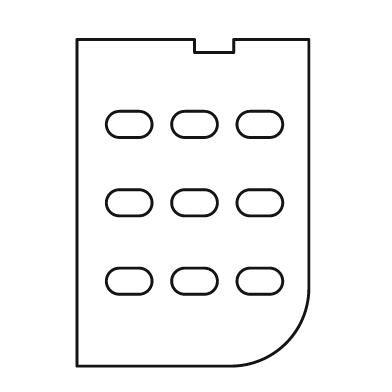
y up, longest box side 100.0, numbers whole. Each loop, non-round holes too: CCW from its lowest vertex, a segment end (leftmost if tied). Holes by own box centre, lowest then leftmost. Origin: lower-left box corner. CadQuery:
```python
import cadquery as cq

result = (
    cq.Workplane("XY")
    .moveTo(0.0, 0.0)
    .lineTo(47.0, 0.0)
    .threePointArc((64.0, 7.0), (71.0, 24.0))
    .lineTo(71.0, 100.0)
    .lineTo(48.0, 100.0)
    .lineTo(48.0, 96.0)
    .lineTo(36.0, 96.0)
    .lineTo(36.0, 100.0)
    .lineTo(0.0, 100.0)
    .close()
    .moveTo(13.0, 22.0)
    .lineTo(19.0, 22.0)
    .threePointArc((23.0, 26.0), (19.0, 30.0))
    .lineTo(13.0, 30.0)
    .threePointArc((9.0, 26.0), (13.0, 22.0))
    .close()
    .moveTo(33.0, 22.0)
    .lineTo(39.0, 22.0)
    .threePointArc((43.0, 26.0), (39.0, 30.0))
    .lineTo(33.0, 30.0)
    .threePointArc((29.0, 26.0), (33.0, 22.0))
    .close()
    .moveTo(53.0, 22.0)
    .lineTo(59.0, 22.0)
    .threePointArc((63.0, 26.0), (59.0, 30.0))
    .lineTo(53.0, 30.0)
    .threePointArc((49.0, 26.0), (53.0, 22.0))
    .close()
    .moveTo(13.0, 46.0)
    .lineTo(19.0, 46.0)
    .threePointArc((23.0, 50.0), (19.0, 54.0))
    .lineTo(13.0, 54.0)
    .threePointArc((9.0, 50.0), (13.0, 46.0))
    .close()
    .moveTo(33.0, 46.0)
    .lineTo(39.0, 46.0)
    .threePointArc((43.0, 50.0), (39.0, 54.0))
    .lineTo(33.0, 54.0)
    .threePointArc((29.0, 50.0), (33.0, 46.0))
    .close()
    .moveTo(53.0, 46.0)
    .lineTo(59.0, 46.0)
    .threePointArc((63.0, 50.0), (59.0, 54.0))
    .lineTo(53.0, 54.0)
    .threePointArc((49.0, 50.0), (53.0, 46.0))
    .close()
    .moveTo(13.0, 70.0)
    .lineTo(19.0, 70.0)
    .threePointArc((23.0, 74.0), (19.0, 78.0))
    .lineTo(13.0, 78.0)
    .threePointArc((9.0, 74.0), (13.0, 70.0))
    .close()
    .moveTo(33.0, 70.0)
    .lineTo(39.0, 70.0)
    .threePointArc((43.0, 74.0), (39.0, 78.0))
    .lineTo(33.0, 78.0)
    .threePointArc((29.0, 74.0), (33.0, 70.0))
    .close()
    .moveTo(53.0, 70.0)
    .lineTo(59.0, 70.0)
    .threePointArc((63.0, 74.0), (59.0, 78.0))
    .lineTo(53.0, 78.0)
    .threePointArc((49.0, 74.0), (53.0, 70.0))
    .close()
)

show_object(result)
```